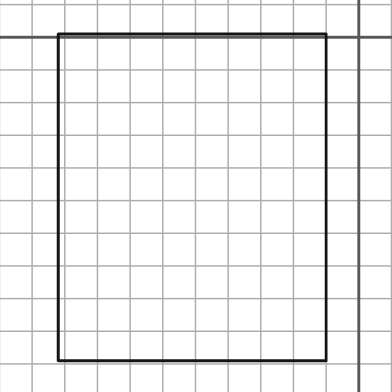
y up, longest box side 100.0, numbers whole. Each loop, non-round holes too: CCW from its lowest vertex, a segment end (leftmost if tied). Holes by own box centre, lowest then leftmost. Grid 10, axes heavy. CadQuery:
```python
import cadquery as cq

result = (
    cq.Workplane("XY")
    .moveTo(-92.0, -99.0)
    .lineTo(-10.0, -99.0)
    .lineTo(-10.0, 1.0)
    .lineTo(-92.0, 1.0)
    .close()
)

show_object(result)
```